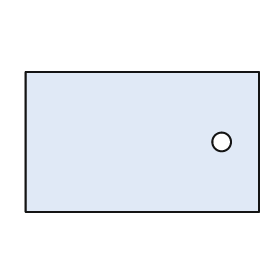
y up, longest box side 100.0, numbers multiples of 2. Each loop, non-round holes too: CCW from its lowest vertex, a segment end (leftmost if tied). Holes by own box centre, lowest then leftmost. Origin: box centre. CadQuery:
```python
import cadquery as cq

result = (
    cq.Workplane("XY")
    .moveTo(-50.0, -30.0)
    .lineTo(50.0, -30.0)
    .lineTo(50.0, 30.0)
    .lineTo(-50.0, 30.0)
    .close()
    .moveTo(34.0, 0.0)
    .circle(4.0)
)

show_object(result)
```